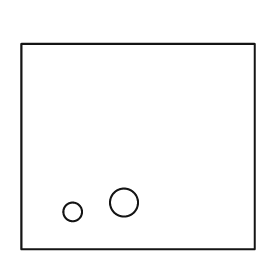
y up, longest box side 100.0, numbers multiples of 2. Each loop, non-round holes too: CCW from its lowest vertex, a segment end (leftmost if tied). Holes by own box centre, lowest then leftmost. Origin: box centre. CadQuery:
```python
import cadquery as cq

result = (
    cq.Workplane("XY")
    .moveTo(-50.0, -44.0)
    .lineTo(50.0, -44.0)
    .lineTo(50.0, 44.0)
    .lineTo(-50.0, 44.0)
    .close()
    .moveTo(-28.0, -28.0)
    .circle(4.0)
    .moveTo(-6.0, -24.0)
    .circle(6.0)
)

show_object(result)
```